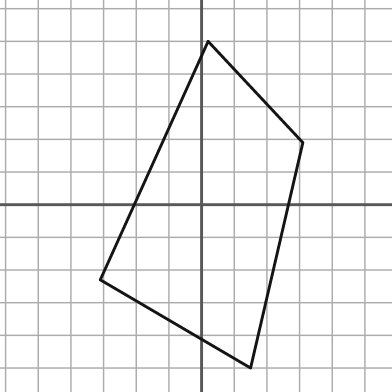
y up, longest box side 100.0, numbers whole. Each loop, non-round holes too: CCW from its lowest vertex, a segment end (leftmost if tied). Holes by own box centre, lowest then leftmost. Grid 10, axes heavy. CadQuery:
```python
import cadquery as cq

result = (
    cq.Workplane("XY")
    .moveTo(15.0, -50.0)
    .lineTo(31.0, 19.0)
    .lineTo(2.0, 50.0)
    .lineTo(-31.0, -23.0)
    .close()
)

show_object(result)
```